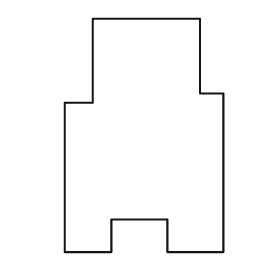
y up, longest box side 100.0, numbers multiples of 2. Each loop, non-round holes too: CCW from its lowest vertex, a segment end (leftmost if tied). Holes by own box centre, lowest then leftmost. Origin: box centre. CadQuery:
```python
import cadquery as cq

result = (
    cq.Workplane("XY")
    .moveTo(-34.0, -50.0)
    .lineTo(-14.0, -50.0)
    .lineTo(-14.0, -36.0)
    .lineTo(10.0, -36.0)
    .lineTo(10.0, -50.0)
    .lineTo(34.0, -50.0)
    .lineTo(34.0, 18.0)
    .lineTo(24.0, 18.0)
    .lineTo(24.0, 50.0)
    .lineTo(-22.0, 50.0)
    .lineTo(-22.0, 14.0)
    .lineTo(-34.0, 14.0)
    .close()
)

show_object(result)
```